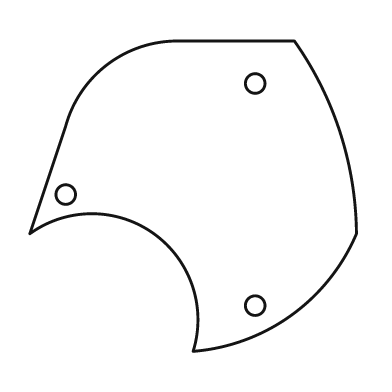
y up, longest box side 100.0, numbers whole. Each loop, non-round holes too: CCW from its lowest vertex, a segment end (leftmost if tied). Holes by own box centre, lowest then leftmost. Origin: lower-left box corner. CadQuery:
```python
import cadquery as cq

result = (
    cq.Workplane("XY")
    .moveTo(50.0, 0.0)
    .threePointArc((80.0, 11.0), (100.0, 36.0))
    .threePointArc((95.0, 67.0), (81.0, 95.0))
    .lineTo(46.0, 95.0)
    .threePointArc((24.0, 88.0), (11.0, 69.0))
    .lineTo(0.0, 36.0)
    .threePointArc((38.0, 36.0), (50.0, 0.0))
    .close()
    .moveTo(69.0, 14.0)
    .circle(3.0)
    .moveTo(11.0, 48.0)
    .circle(3.0)
    .moveTo(69.0, 82.0)
    .circle(3.0)
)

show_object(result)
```